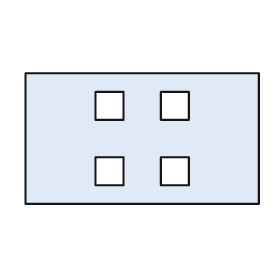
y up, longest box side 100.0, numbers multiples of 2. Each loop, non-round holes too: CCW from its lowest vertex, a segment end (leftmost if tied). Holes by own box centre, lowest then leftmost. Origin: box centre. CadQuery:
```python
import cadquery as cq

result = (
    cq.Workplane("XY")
    .moveTo(-50.0, -28.0)
    .lineTo(50.0, -28.0)
    .lineTo(50.0, 28.0)
    .lineTo(-50.0, 28.0)
    .close()
    .moveTo(-20.0, -20.0)
    .lineTo(-8.0, -20.0)
    .lineTo(-8.0, -8.0)
    .lineTo(-20.0, -8.0)
    .close()
    .moveTo(8.0, -20.0)
    .lineTo(20.0, -20.0)
    .lineTo(20.0, -8.0)
    .lineTo(8.0, -8.0)
    .close()
    .moveTo(-20.0, 8.0)
    .lineTo(-8.0, 8.0)
    .lineTo(-8.0, 20.0)
    .lineTo(-20.0, 20.0)
    .close()
    .moveTo(8.0, 8.0)
    .lineTo(20.0, 8.0)
    .lineTo(20.0, 20.0)
    .lineTo(8.0, 20.0)
    .close()
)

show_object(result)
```